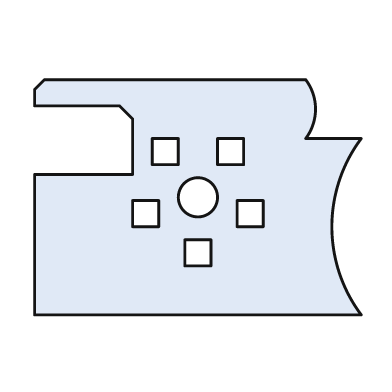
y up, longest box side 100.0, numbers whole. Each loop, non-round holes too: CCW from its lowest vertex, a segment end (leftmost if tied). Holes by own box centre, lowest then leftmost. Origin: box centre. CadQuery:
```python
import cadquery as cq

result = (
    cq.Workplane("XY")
    .moveTo(-50.0, -36.0)
    .lineTo(50.0, -36.0)
    .threePointArc((41.0, -9.0), (50.0, 18.0))
    .lineTo(33.0, 18.0)
    .threePointArc((36.0, 27.0), (33.0, 36.0))
    .lineTo(-47.0, 36.0)
    .lineTo(-50.0, 33.0)
    .lineTo(-50.0, 28.0)
    .lineTo(-24.0, 28.0)
    .lineTo(-20.0, 24.0)
    .lineTo(-20.0, 7.0)
    .lineTo(-50.0, 7.0)
    .close()
    .moveTo(-4.0, -21.0)
    .lineTo(4.0, -21.0)
    .lineTo(4.0, -13.0)
    .lineTo(-4.0, -13.0)
    .close()
    .moveTo(-20.0, -9.0)
    .lineTo(-12.0, -9.0)
    .lineTo(-12.0, -1.0)
    .lineTo(-20.0, -1.0)
    .close()
    .moveTo(12.0, -9.0)
    .lineTo(20.0, -9.0)
    .lineTo(20.0, -1.0)
    .lineTo(12.0, -1.0)
    .close()
    .moveTo(0.0, 0.0)
    .circle(6.0)
    .moveTo(-14.0, 10.0)
    .lineTo(-6.0, 10.0)
    .lineTo(-6.0, 18.0)
    .lineTo(-14.0, 18.0)
    .close()
    .moveTo(6.0, 10.0)
    .lineTo(14.0, 10.0)
    .lineTo(14.0, 18.0)
    .lineTo(6.0, 18.0)
    .close()
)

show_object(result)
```